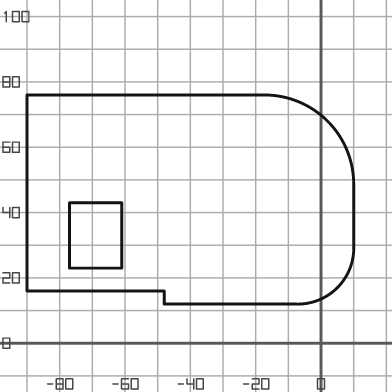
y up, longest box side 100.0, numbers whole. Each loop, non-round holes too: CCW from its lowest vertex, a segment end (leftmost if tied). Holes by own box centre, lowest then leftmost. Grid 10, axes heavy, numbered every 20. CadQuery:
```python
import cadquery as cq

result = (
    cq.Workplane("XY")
    .moveTo(-48.0, 12.0)
    .lineTo(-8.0, 12.0)
    .threePointArc((5.0, 17.0), (10.0, 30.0))
    .lineTo(10.0, 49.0)
    .threePointArc((2.0, 68.0), (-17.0, 76.0))
    .lineTo(-90.0, 76.0)
    .lineTo(-90.0, 16.0)
    .lineTo(-48.0, 16.0)
    .close()
    .moveTo(-77.0, 23.0)
    .lineTo(-61.0, 23.0)
    .lineTo(-61.0, 43.0)
    .lineTo(-77.0, 43.0)
    .close()
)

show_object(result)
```